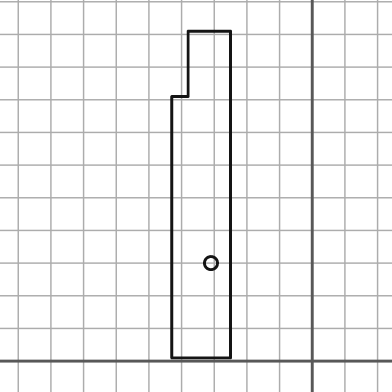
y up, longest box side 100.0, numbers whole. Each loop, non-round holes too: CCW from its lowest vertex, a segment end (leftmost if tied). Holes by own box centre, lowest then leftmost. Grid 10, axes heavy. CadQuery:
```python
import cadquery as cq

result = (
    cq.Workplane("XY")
    .moveTo(-43.0, 1.0)
    .lineTo(-25.0, 1.0)
    .lineTo(-25.0, 101.0)
    .lineTo(-38.0, 101.0)
    .lineTo(-38.0, 81.0)
    .lineTo(-43.0, 81.0)
    .close()
    .moveTo(-31.0, 30.0)
    .circle(2.0)
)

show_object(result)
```